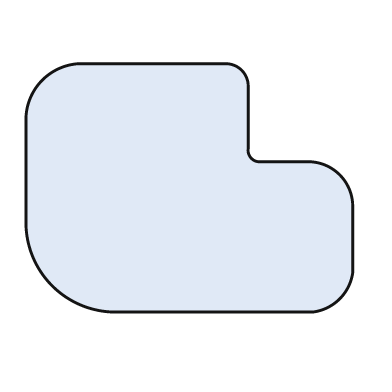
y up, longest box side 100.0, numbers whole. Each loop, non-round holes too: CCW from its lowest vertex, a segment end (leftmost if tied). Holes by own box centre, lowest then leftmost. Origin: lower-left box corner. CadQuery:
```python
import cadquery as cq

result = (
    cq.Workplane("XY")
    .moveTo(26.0, 0.0)
    .lineTo(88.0, 0.0)
    .threePointArc((96.0, 4.0), (100.0, 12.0))
    .lineTo(100.0, 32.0)
    .threePointArc((96.0, 42.0), (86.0, 46.0))
    .lineTo(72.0, 46.0)
    .threePointArc((69.0, 47.0), (68.0, 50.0))
    .lineTo(68.0, 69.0)
    .threePointArc((66.0, 74.0), (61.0, 76.0))
    .lineTo(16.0, 76.0)
    .threePointArc((5.0, 71.0), (0.0, 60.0))
    .lineTo(0.0, 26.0)
    .threePointArc((8.0, 8.0), (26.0, 0.0))
    .close()
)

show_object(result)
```